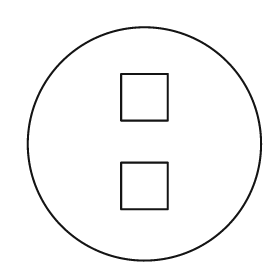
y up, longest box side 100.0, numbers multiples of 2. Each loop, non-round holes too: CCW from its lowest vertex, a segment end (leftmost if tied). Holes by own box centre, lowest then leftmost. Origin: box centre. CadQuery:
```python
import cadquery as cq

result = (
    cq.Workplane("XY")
    .moveTo(0.0, 0.0)
    .circle(50.0)
    .moveTo(-10.0, -28.0)
    .lineTo(10.0, -28.0)
    .lineTo(10.0, -8.0)
    .lineTo(-10.0, -8.0)
    .close()
    .moveTo(-10.0, 10.0)
    .lineTo(10.0, 10.0)
    .lineTo(10.0, 30.0)
    .lineTo(-10.0, 30.0)
    .close()
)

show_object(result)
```